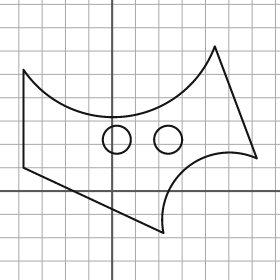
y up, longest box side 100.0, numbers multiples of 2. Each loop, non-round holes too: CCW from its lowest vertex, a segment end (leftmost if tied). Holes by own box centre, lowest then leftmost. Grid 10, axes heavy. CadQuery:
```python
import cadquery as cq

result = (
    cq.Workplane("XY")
    .moveTo(22.0, -18.0)
    .threePointArc((32.0, 10.0), (62.0, 14.0))
    .lineTo(44.0, 62.0)
    .threePointArc((6.0, 32.0), (-38.0, 52.0))
    .lineTo(-38.0, 10.0)
    .close()
    .moveTo(2.0, 22.0)
    .circle(6.0)
    .moveTo(24.0, 22.0)
    .circle(6.0)
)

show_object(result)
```